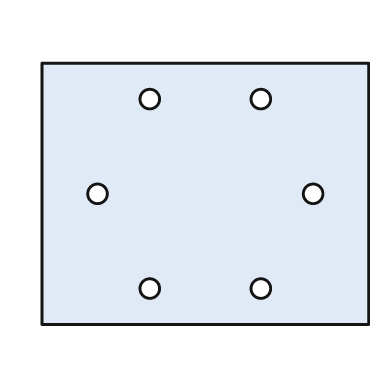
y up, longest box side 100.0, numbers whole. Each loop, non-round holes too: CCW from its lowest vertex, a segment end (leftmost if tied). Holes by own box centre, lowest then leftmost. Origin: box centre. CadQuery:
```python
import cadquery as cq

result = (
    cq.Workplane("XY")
    .moveTo(-50.0, -40.0)
    .lineTo(50.0, -40.0)
    .lineTo(50.0, 40.0)
    .lineTo(-50.0, 40.0)
    .close()
    .moveTo(-17.0, -29.0)
    .circle(3.0)
    .moveTo(17.0, -29.0)
    .circle(3.0)
    .moveTo(-33.0, 0.0)
    .circle(3.0)
    .moveTo(33.0, 0.0)
    .circle(3.0)
    .moveTo(-17.0, 29.0)
    .circle(3.0)
    .moveTo(17.0, 29.0)
    .circle(3.0)
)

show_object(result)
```